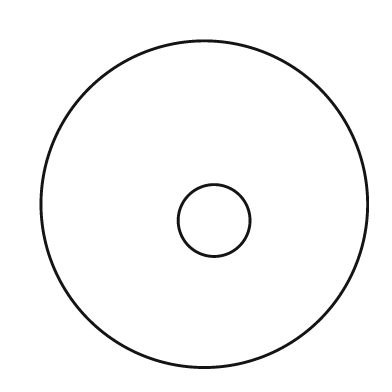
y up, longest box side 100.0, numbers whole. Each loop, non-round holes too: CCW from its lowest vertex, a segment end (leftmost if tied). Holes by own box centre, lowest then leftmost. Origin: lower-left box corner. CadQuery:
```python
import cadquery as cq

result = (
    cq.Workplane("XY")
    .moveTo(50.0, 50.0)
    .circle(50.0)
    .moveTo(53.0, 45.0)
    .circle(11.0)
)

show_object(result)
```